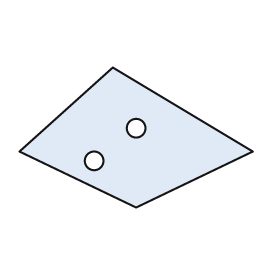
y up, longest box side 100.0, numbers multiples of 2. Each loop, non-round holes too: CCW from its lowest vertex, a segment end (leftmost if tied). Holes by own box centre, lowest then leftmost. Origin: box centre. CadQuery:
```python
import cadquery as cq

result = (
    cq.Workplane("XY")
    .moveTo(0.0, -30.0)
    .lineTo(50.0, -6.0)
    .lineTo(-10.0, 30.0)
    .lineTo(-50.0, -6.0)
    .close()
    .moveTo(-18.0, -10.0)
    .circle(4.0)
    .moveTo(0.0, 4.0)
    .circle(4.0)
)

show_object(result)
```